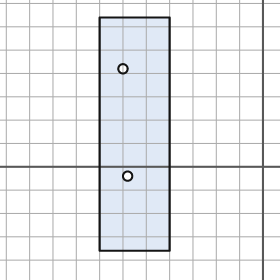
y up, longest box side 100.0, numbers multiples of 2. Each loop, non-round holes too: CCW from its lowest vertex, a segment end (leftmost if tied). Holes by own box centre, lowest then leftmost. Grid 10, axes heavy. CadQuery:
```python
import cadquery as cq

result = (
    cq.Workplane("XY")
    .moveTo(-70.0, -36.0)
    .lineTo(-40.0, -36.0)
    .lineTo(-40.0, 64.0)
    .lineTo(-70.0, 64.0)
    .close()
    .moveTo(-58.0, -4.0)
    .circle(2.0)
    .moveTo(-60.0, 42.0)
    .circle(2.0)
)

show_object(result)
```